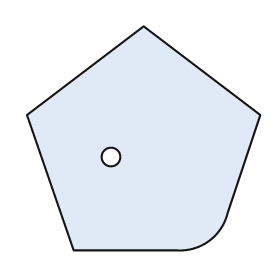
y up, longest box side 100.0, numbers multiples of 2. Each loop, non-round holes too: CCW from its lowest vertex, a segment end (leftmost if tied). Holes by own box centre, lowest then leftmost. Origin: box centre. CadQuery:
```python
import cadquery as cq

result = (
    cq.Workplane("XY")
    .moveTo(-30.0, -48.0)
    .lineTo(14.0, -48.0)
    .threePointArc((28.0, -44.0), (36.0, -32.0))
    .lineTo(50.0, 10.0)
    .lineTo(0.0, 48.0)
    .lineTo(-50.0, 10.0)
    .close()
    .moveTo(-14.0, -8.0)
    .circle(4.0)
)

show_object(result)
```